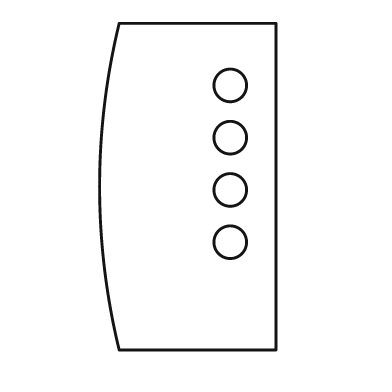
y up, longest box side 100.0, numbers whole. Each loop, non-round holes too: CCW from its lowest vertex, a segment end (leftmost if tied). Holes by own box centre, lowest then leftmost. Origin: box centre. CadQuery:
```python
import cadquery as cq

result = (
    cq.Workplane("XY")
    .moveTo(-21.0, -50.0)
    .lineTo(27.0, -50.0)
    .lineTo(27.0, 50.0)
    .lineTo(-21.0, 50.0)
    .threePointArc((-27.0, 0.0), (-21.0, -50.0))
    .close()
    .moveTo(13.0, -17.0)
    .circle(5.0)
    .moveTo(13.0, -1.0)
    .circle(5.0)
    .moveTo(13.0, 15.0)
    .circle(5.0)
    .moveTo(13.0, 31.0)
    .circle(5.0)
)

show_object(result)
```